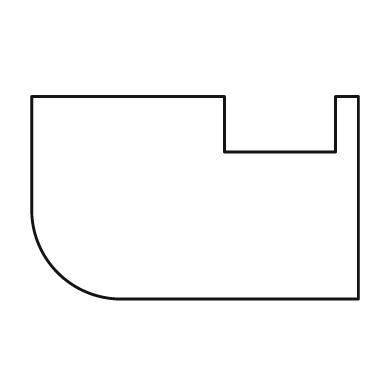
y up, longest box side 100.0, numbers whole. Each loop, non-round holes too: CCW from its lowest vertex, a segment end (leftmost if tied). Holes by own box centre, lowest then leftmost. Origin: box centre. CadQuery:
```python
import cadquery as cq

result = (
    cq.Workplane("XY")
    .moveTo(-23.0, -31.0)
    .lineTo(50.0, -31.0)
    .lineTo(50.0, 31.0)
    .lineTo(43.0, 31.0)
    .lineTo(43.0, 14.0)
    .lineTo(9.0, 14.0)
    .lineTo(9.0, 31.0)
    .lineTo(-50.0, 31.0)
    .lineTo(-50.0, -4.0)
    .threePointArc((-42.0, -23.0), (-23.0, -31.0))
    .close()
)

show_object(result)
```